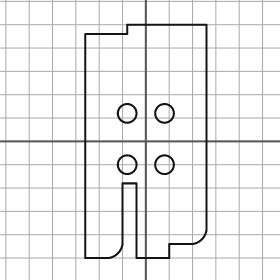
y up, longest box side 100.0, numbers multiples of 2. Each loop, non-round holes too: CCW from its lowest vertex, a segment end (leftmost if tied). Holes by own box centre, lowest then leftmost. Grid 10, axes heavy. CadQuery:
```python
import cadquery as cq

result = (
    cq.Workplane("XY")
    .moveTo(-26.0, -50.0)
    .lineTo(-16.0, -50.0)
    .threePointArc((-12.0, -48.0), (-10.0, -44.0))
    .lineTo(-10.0, -18.0)
    .lineTo(-4.0, -18.0)
    .lineTo(-4.0, -50.0)
    .lineTo(10.0, -50.0)
    .lineTo(10.0, -44.0)
    .lineTo(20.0, -44.0)
    .threePointArc((24.0, -42.0), (26.0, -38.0))
    .lineTo(26.0, 50.0)
    .lineTo(-8.0, 50.0)
    .lineTo(-8.0, 46.0)
    .lineTo(-26.0, 46.0)
    .close()
    .moveTo(-8.0, -10.0)
    .circle(4.0)
    .moveTo(8.0, -10.0)
    .circle(4.0)
    .moveTo(-8.0, 12.0)
    .circle(4.0)
    .moveTo(8.0, 12.0)
    .circle(4.0)
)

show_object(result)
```